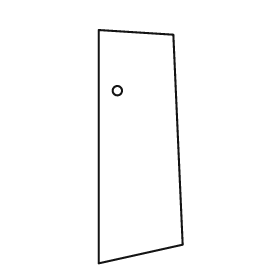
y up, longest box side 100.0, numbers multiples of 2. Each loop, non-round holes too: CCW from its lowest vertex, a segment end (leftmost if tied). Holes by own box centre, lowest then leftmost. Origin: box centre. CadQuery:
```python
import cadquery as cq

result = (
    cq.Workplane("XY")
    .moveTo(-18.0, -50.0)
    .lineTo(18.0, -42.0)
    .lineTo(14.0, 48.0)
    .lineTo(-18.0, 50.0)
    .close()
    .moveTo(-10.0, 24.0)
    .circle(2.0)
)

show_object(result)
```